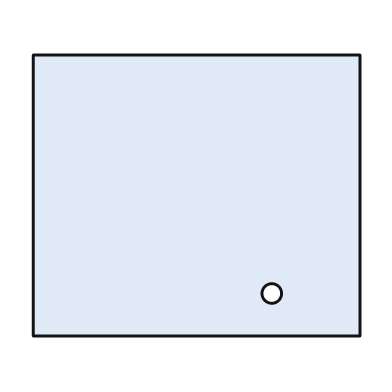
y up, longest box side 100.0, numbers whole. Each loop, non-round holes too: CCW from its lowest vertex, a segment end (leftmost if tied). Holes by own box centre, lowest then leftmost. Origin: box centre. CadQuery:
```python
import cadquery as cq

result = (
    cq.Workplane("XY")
    .moveTo(-50.0, -43.0)
    .lineTo(50.0, -43.0)
    .lineTo(50.0, 43.0)
    .lineTo(-50.0, 43.0)
    .close()
    .moveTo(23.0, -30.0)
    .circle(3.0)
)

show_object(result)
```